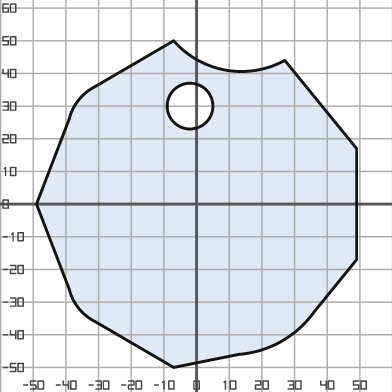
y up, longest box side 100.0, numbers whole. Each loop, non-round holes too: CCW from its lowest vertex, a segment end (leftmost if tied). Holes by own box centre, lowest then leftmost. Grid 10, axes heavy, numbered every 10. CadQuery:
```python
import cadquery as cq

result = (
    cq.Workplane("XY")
    .moveTo(-7.0, -50.0)
    .lineTo(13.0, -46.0)
    .threePointArc((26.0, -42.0), (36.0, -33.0))
    .lineTo(49.0, -17.0)
    .lineTo(49.0, 17.0)
    .lineTo(27.0, 44.0)
    .threePointArc((9.0, 41.0), (-7.0, 50.0))
    .lineTo(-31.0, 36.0)
    .threePointArc((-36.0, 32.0), (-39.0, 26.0))
    .lineTo(-49.0, 0.0)
    .lineTo(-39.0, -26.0)
    .threePointArc((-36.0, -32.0), (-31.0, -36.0))
    .close()
    .moveTo(-2.0, 30.0)
    .circle(7.0)
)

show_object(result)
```